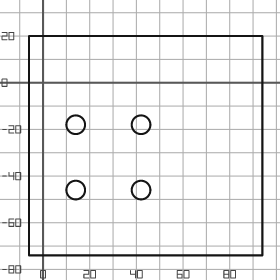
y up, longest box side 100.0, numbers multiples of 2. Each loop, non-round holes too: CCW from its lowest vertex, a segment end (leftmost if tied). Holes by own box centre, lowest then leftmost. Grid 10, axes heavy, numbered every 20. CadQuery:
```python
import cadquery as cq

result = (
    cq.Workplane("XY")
    .moveTo(-6.0, -74.0)
    .lineTo(94.0, -74.0)
    .lineTo(94.0, 20.0)
    .lineTo(-6.0, 20.0)
    .close()
    .moveTo(14.0, -46.0)
    .circle(4.0)
    .moveTo(42.0, -46.0)
    .circle(4.0)
    .moveTo(14.0, -18.0)
    .circle(4.0)
    .moveTo(42.0, -18.0)
    .circle(4.0)
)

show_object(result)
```